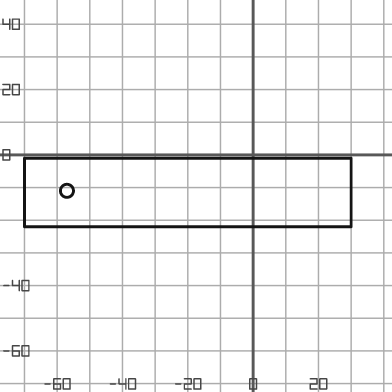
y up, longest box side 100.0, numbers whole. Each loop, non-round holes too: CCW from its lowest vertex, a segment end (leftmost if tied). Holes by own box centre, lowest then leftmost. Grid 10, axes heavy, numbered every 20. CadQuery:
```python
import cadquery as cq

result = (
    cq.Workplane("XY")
    .moveTo(-70.0, -22.0)
    .lineTo(30.0, -22.0)
    .lineTo(30.0, -1.0)
    .lineTo(-70.0, -1.0)
    .close()
    .moveTo(-57.0, -11.0)
    .circle(2.0)
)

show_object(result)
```